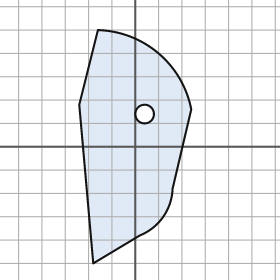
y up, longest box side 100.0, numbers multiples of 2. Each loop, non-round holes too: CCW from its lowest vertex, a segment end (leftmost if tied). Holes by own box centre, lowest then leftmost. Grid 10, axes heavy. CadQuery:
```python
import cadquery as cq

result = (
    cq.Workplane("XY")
    .moveTo(-18.0, -50.0)
    .lineTo(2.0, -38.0)
    .threePointArc((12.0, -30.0), (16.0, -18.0))
    .lineTo(24.0, 16.0)
    .threePointArc((10.0, 40.0), (-16.0, 50.0))
    .lineTo(-24.0, 18.0)
    .close()
    .moveTo(4.0, 14.0)
    .circle(4.0)
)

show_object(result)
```